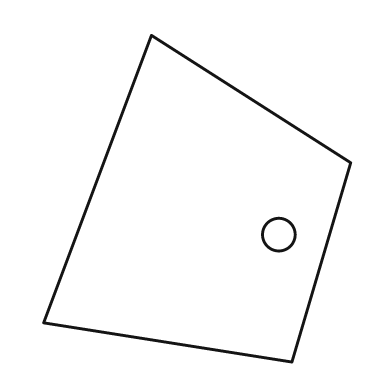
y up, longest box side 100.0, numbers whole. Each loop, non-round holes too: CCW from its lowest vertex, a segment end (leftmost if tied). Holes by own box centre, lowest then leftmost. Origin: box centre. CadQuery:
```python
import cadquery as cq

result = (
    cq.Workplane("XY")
    .moveTo(29.0, -50.0)
    .lineTo(47.0, 11.0)
    .lineTo(-14.0, 50.0)
    .lineTo(-47.0, -38.0)
    .close()
    .moveTo(25.0, -11.0)
    .circle(5.0)
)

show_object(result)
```